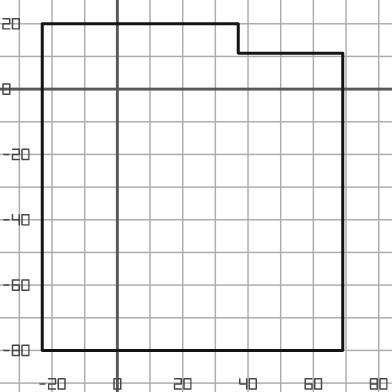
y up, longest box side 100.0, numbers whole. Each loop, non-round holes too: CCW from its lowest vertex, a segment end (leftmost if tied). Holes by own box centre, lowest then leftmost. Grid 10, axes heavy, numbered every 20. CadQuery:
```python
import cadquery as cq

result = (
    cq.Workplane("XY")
    .moveTo(-23.0, -80.0)
    .lineTo(69.0, -80.0)
    .lineTo(69.0, 11.0)
    .lineTo(37.0, 11.0)
    .lineTo(37.0, 20.0)
    .lineTo(-23.0, 20.0)
    .close()
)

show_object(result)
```